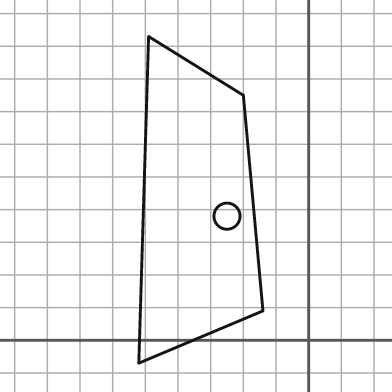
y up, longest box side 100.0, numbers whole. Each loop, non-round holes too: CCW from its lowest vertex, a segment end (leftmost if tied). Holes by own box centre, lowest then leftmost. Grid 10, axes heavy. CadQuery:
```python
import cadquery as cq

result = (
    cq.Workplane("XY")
    .moveTo(-52.0, -7.0)
    .lineTo(-14.0, 9.0)
    .lineTo(-20.0, 75.0)
    .lineTo(-49.0, 93.0)
    .close()
    .moveTo(-25.0, 38.0)
    .circle(4.0)
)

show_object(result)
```